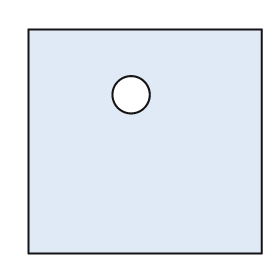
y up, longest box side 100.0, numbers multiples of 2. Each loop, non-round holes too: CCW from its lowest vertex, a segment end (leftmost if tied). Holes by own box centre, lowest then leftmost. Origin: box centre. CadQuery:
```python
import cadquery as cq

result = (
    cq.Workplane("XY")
    .moveTo(-50.0, -48.0)
    .lineTo(50.0, -48.0)
    .lineTo(50.0, 48.0)
    .lineTo(-50.0, 48.0)
    .close()
    .moveTo(-6.0, 20.0)
    .circle(8.0)
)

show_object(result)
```